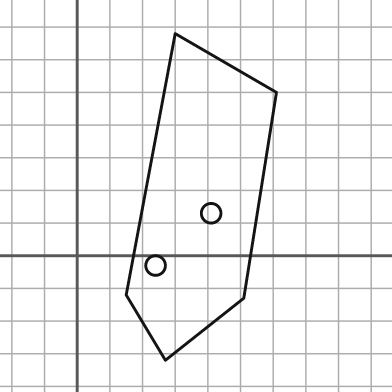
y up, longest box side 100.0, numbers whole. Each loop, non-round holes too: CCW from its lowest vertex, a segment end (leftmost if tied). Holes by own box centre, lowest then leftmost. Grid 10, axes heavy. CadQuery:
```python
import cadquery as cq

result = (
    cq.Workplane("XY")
    .moveTo(27.0, -32.0)
    .lineTo(51.0, -13.0)
    .lineTo(61.0, 50.0)
    .lineTo(30.0, 68.0)
    .lineTo(15.0, -12.0)
    .close()
    .moveTo(24.0, -3.0)
    .circle(3.0)
    .moveTo(41.0, 13.0)
    .circle(3.0)
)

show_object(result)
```